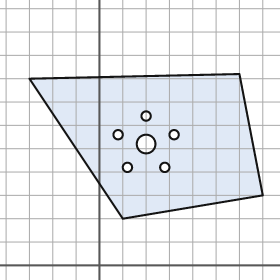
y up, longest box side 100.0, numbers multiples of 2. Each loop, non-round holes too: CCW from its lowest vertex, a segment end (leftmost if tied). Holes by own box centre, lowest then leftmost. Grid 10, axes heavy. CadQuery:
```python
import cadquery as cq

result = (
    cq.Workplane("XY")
    .moveTo(10.0, 20.0)
    .lineTo(70.0, 30.0)
    .lineTo(60.0, 82.0)
    .lineTo(-30.0, 80.0)
    .close()
    .moveTo(12.0, 42.0)
    .circle(2.0)
    .moveTo(28.0, 42.0)
    .circle(2.0)
    .moveTo(20.0, 52.0)
    .circle(4.0)
    .moveTo(8.0, 56.0)
    .circle(2.0)
    .moveTo(32.0, 56.0)
    .circle(2.0)
    .moveTo(20.0, 64.0)
    .circle(2.0)
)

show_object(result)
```